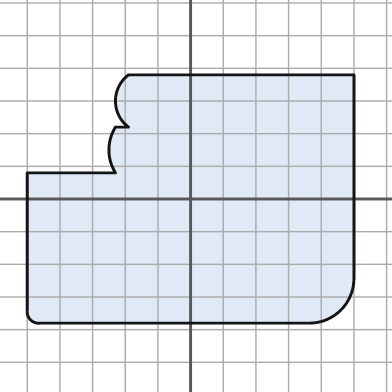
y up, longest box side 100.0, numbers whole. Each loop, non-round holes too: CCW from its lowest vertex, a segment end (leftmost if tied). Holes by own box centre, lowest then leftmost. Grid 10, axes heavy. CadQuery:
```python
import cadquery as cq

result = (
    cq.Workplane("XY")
    .moveTo(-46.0, -38.0)
    .lineTo(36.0, -38.0)
    .threePointArc((46.0, -34.0), (50.0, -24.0))
    .lineTo(50.0, 38.0)
    .lineTo(-19.0, 38.0)
    .threePointArc((-23.0, 30.0), (-19.0, 22.0))
    .lineTo(-23.0, 22.0)
    .threePointArc((-25.0, 15.0), (-23.0, 8.0))
    .lineTo(-50.0, 8.0)
    .lineTo(-50.0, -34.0)
    .threePointArc((-49.0, -37.0), (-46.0, -38.0))
    .close()
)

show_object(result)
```